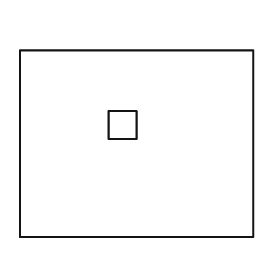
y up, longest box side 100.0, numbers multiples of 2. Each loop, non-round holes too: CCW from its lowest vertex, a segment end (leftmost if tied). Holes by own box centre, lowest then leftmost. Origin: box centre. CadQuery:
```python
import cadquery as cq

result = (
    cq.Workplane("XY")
    .moveTo(-50.0, -40.0)
    .lineTo(50.0, -40.0)
    .lineTo(50.0, 40.0)
    .lineTo(-50.0, 40.0)
    .close()
    .moveTo(-12.0, 2.0)
    .lineTo(0.0, 2.0)
    .lineTo(0.0, 14.0)
    .lineTo(-12.0, 14.0)
    .close()
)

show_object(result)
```